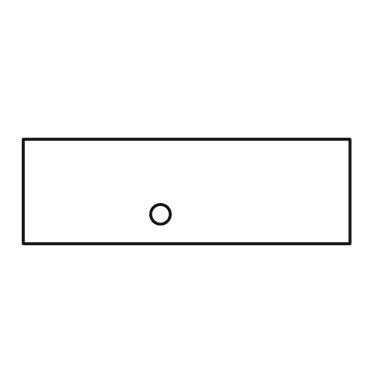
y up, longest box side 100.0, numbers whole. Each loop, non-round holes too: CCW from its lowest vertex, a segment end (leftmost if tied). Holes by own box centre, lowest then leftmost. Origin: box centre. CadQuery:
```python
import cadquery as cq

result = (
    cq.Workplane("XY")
    .moveTo(-50.0, -16.0)
    .lineTo(50.0, -16.0)
    .lineTo(50.0, 16.0)
    .lineTo(-50.0, 16.0)
    .close()
    .moveTo(-8.0, -7.0)
    .circle(3.0)
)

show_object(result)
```